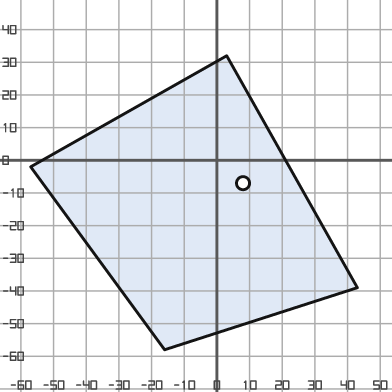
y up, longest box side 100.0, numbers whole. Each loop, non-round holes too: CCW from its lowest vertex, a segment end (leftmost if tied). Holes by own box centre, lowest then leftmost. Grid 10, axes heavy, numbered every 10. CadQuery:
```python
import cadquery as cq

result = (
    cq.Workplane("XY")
    .moveTo(-16.0, -58.0)
    .lineTo(43.0, -39.0)
    .lineTo(3.0, 32.0)
    .lineTo(-57.0, -2.0)
    .close()
    .moveTo(8.0, -7.0)
    .circle(2.0)
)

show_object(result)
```